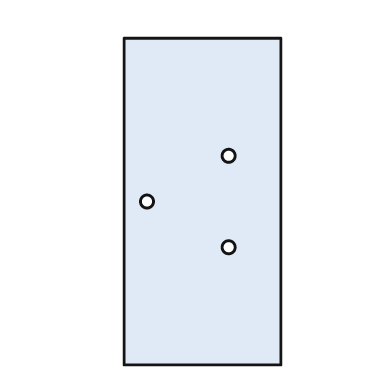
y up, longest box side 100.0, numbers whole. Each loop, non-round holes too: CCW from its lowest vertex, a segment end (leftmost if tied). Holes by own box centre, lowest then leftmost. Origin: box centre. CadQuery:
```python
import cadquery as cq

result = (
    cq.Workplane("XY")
    .moveTo(-24.0, -50.0)
    .lineTo(24.0, -50.0)
    .lineTo(24.0, 50.0)
    .lineTo(-24.0, 50.0)
    .close()
    .moveTo(8.0, -14.0)
    .circle(2.0)
    .moveTo(-17.0, 0.0)
    .circle(2.0)
    .moveTo(8.0, 14.0)
    .circle(2.0)
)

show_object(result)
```